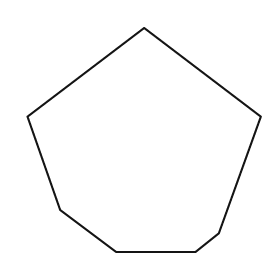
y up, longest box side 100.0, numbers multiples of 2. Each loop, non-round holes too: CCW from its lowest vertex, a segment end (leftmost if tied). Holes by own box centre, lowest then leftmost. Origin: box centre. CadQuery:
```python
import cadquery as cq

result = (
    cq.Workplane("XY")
    .moveTo(-12.0, -48.0)
    .lineTo(22.0, -48.0)
    .lineTo(32.0, -40.0)
    .lineTo(50.0, 10.0)
    .lineTo(0.0, 48.0)
    .lineTo(-50.0, 10.0)
    .lineTo(-36.0, -30.0)
    .close()
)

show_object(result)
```